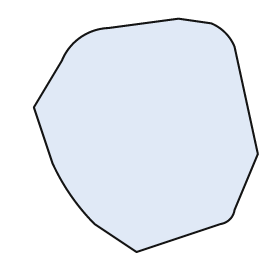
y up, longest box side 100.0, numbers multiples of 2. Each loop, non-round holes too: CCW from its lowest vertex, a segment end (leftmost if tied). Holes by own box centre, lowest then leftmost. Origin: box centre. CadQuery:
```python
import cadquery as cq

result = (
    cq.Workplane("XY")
    .moveTo(-4.0, -50.0)
    .lineTo(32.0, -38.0)
    .threePointArc((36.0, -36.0), (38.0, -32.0))
    .lineTo(48.0, -8.0)
    .lineTo(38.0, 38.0)
    .threePointArc((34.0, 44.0), (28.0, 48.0))
    .lineTo(14.0, 50.0)
    .lineTo(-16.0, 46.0)
    .threePointArc((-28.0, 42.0), (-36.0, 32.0))
    .lineTo(-48.0, 12.0)
    .lineTo(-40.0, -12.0)
    .threePointArc((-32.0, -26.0), (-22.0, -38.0))
    .close()
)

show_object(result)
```